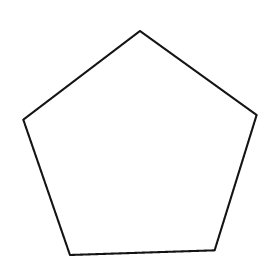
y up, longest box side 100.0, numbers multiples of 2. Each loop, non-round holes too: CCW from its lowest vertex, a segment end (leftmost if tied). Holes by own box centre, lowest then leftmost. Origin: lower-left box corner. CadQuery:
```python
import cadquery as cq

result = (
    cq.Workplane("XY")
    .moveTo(20.0, 0.0)
    .lineTo(82.0, 2.0)
    .lineTo(100.0, 60.0)
    .lineTo(50.0, 96.0)
    .lineTo(0.0, 58.0)
    .close()
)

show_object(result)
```